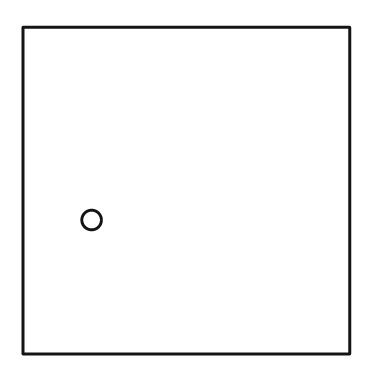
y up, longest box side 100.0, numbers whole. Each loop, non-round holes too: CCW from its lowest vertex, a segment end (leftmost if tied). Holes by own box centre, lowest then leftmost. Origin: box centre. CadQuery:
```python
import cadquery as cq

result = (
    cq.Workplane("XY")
    .moveTo(-50.0, -50.0)
    .lineTo(50.0, -50.0)
    .lineTo(50.0, 50.0)
    .lineTo(-50.0, 50.0)
    .close()
    .moveTo(-29.0, -9.0)
    .circle(3.0)
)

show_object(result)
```